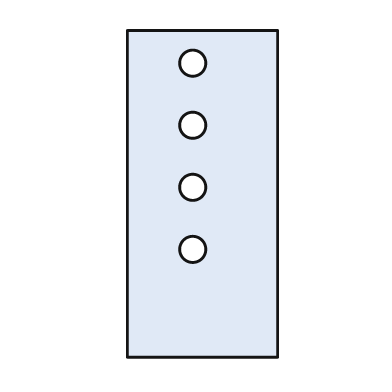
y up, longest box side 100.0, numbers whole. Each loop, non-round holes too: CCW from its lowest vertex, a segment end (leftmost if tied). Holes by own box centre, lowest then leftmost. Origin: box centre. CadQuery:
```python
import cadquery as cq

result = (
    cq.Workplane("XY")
    .moveTo(-23.0, -50.0)
    .lineTo(23.0, -50.0)
    .lineTo(23.0, 50.0)
    .lineTo(-23.0, 50.0)
    .close()
    .moveTo(-3.0, -17.0)
    .circle(4.0)
    .moveTo(-3.0, 2.0)
    .circle(4.0)
    .moveTo(-3.0, 21.0)
    .circle(4.0)
    .moveTo(-3.0, 40.0)
    .circle(4.0)
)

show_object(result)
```